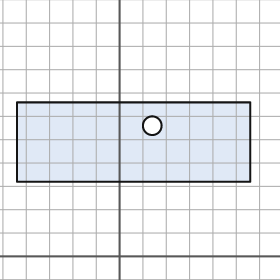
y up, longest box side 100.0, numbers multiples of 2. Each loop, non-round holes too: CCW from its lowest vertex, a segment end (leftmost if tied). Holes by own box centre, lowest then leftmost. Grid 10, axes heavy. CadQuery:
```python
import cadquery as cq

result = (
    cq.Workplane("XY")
    .moveTo(-44.0, 32.0)
    .lineTo(56.0, 32.0)
    .lineTo(56.0, 66.0)
    .lineTo(-44.0, 66.0)
    .close()
    .moveTo(14.0, 56.0)
    .circle(4.0)
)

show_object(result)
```